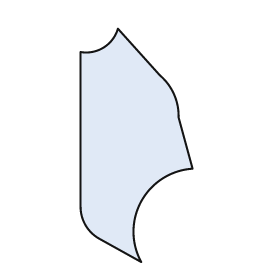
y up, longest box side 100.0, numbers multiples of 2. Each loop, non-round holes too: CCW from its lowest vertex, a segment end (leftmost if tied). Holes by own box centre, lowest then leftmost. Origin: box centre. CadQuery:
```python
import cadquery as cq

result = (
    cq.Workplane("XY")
    .moveTo(2.0, -50.0)
    .threePointArc((2.0, -24.0), (24.0, -10.0))
    .lineTo(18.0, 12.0)
    .threePointArc((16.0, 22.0), (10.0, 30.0))
    .lineTo(-8.0, 50.0)
    .threePointArc((-14.0, 42.0), (-24.0, 40.0))
    .lineTo(-24.0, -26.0)
    .threePointArc((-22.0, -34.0), (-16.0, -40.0))
    .close()
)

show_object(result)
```